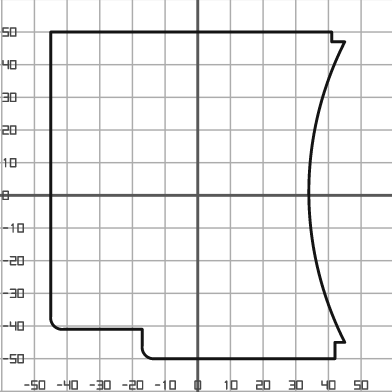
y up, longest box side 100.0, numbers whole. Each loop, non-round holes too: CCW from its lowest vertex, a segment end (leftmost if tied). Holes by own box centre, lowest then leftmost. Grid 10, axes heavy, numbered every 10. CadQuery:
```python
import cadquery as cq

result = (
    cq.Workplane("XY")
    .moveTo(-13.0, -50.0)
    .lineTo(42.0, -50.0)
    .lineTo(42.0, -45.0)
    .lineTo(45.0, -45.0)
    .threePointArc((34.0, 1.0), (45.0, 47.0))
    .lineTo(41.0, 47.0)
    .lineTo(41.0, 50.0)
    .lineTo(-45.0, 50.0)
    .lineTo(-45.0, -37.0)
    .threePointArc((-44.0, -40.0), (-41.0, -41.0))
    .lineTo(-17.0, -41.0)
    .lineTo(-17.0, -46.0)
    .threePointArc((-16.0, -49.0), (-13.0, -50.0))
    .close()
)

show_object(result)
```